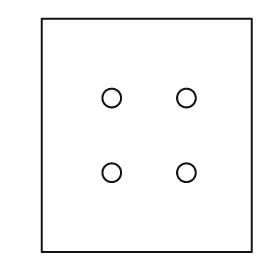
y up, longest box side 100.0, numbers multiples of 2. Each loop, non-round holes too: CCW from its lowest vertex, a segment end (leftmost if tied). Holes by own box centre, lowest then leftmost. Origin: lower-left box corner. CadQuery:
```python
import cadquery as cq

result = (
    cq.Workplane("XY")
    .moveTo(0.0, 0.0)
    .lineTo(90.0, 0.0)
    .lineTo(90.0, 100.0)
    .lineTo(0.0, 100.0)
    .close()
    .moveTo(30.0, 34.0)
    .circle(4.0)
    .moveTo(62.0, 34.0)
    .circle(4.0)
    .moveTo(30.0, 66.0)
    .circle(4.0)
    .moveTo(62.0, 66.0)
    .circle(4.0)
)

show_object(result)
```